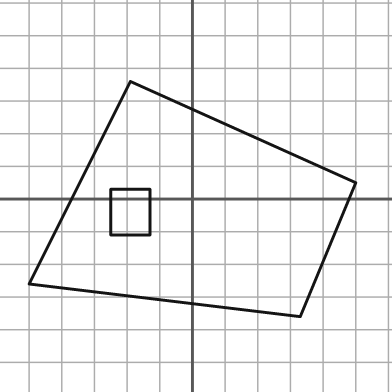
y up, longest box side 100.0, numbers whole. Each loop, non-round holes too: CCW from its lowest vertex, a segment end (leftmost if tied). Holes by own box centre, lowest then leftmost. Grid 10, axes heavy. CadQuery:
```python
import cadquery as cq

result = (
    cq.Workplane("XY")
    .moveTo(33.0, -36.0)
    .lineTo(50.0, 5.0)
    .lineTo(-19.0, 36.0)
    .lineTo(-50.0, -26.0)
    .close()
    .moveTo(-25.0, -11.0)
    .lineTo(-13.0, -11.0)
    .lineTo(-13.0, 3.0)
    .lineTo(-25.0, 3.0)
    .close()
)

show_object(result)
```